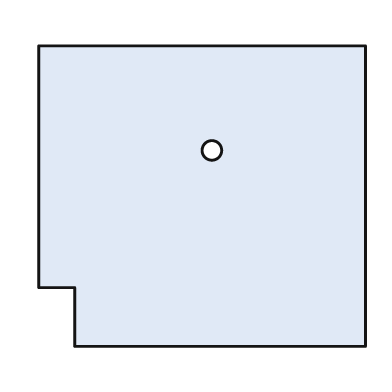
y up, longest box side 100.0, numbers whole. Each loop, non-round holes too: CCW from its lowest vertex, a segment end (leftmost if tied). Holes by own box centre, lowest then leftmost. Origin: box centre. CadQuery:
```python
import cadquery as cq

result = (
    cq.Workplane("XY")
    .moveTo(-39.0, -46.0)
    .lineTo(50.0, -46.0)
    .lineTo(50.0, 46.0)
    .lineTo(-50.0, 46.0)
    .lineTo(-50.0, -28.0)
    .lineTo(-39.0, -28.0)
    .close()
    .moveTo(3.0, 14.0)
    .circle(3.0)
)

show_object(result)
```